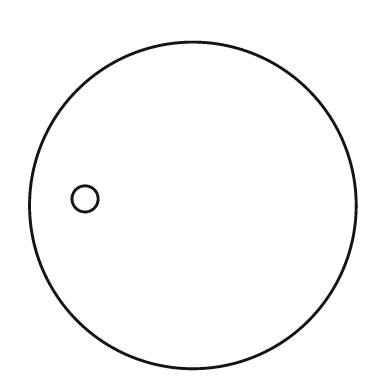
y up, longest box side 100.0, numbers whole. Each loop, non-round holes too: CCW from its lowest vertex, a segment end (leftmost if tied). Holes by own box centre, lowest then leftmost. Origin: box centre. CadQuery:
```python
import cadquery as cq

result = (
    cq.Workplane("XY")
    .moveTo(0.0, 0.0)
    .circle(50.0)
    .moveTo(-33.0, 2.0)
    .circle(4.0)
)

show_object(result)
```